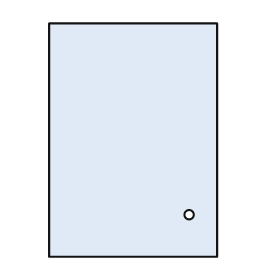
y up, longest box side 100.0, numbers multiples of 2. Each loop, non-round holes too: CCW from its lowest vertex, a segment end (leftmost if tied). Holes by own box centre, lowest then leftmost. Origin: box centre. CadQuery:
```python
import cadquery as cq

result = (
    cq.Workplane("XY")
    .moveTo(-36.0, -50.0)
    .lineTo(36.0, -50.0)
    .lineTo(36.0, 50.0)
    .lineTo(-36.0, 50.0)
    .close()
    .moveTo(24.0, -32.0)
    .circle(2.0)
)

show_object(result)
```